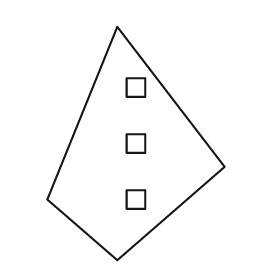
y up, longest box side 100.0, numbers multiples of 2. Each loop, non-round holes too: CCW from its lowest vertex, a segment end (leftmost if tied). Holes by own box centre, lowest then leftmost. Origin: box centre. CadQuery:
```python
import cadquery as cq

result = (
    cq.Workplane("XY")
    .moveTo(-8.0, -50.0)
    .lineTo(38.0, -10.0)
    .lineTo(-8.0, 50.0)
    .lineTo(-38.0, -24.0)
    .close()
    .moveTo(-4.0, -28.0)
    .lineTo(4.0, -28.0)
    .lineTo(4.0, -20.0)
    .lineTo(-4.0, -20.0)
    .close()
    .moveTo(-4.0, -4.0)
    .lineTo(4.0, -4.0)
    .lineTo(4.0, 4.0)
    .lineTo(-4.0, 4.0)
    .close()
    .moveTo(-4.0, 20.0)
    .lineTo(4.0, 20.0)
    .lineTo(4.0, 28.0)
    .lineTo(-4.0, 28.0)
    .close()
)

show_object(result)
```